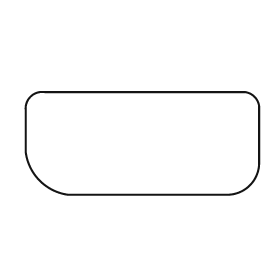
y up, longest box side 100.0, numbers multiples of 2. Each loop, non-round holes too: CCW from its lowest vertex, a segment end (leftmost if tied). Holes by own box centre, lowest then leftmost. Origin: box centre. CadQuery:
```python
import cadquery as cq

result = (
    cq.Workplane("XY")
    .moveTo(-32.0, -22.0)
    .lineTo(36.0, -22.0)
    .threePointArc((46.0, -18.0), (50.0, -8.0))
    .lineTo(50.0, 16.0)
    .threePointArc((48.0, 20.0), (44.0, 22.0))
    .lineTo(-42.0, 22.0)
    .threePointArc((-48.0, 20.0), (-50.0, 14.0))
    .lineTo(-50.0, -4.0)
    .threePointArc((-44.0, -16.0), (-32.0, -22.0))
    .close()
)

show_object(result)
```